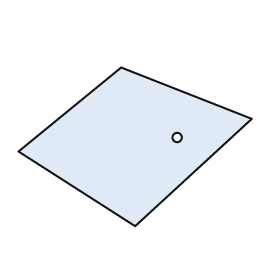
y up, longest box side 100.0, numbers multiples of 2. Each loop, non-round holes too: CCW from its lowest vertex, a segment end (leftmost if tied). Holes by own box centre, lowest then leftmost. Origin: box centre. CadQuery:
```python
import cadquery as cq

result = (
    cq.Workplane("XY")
    .moveTo(0.0, -34.0)
    .lineTo(50.0, 12.0)
    .lineTo(-6.0, 34.0)
    .lineTo(-50.0, -2.0)
    .close()
    .moveTo(18.0, 4.0)
    .circle(2.0)
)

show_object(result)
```